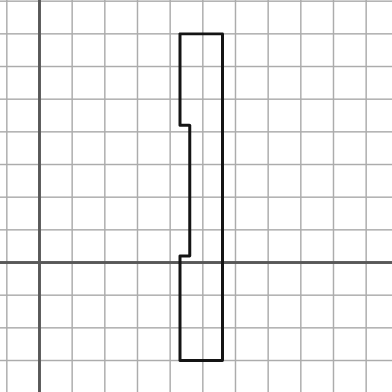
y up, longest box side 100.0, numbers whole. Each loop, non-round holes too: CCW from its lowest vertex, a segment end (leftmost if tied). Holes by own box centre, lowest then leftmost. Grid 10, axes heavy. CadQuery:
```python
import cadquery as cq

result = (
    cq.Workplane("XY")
    .moveTo(43.0, -30.0)
    .lineTo(56.0, -30.0)
    .lineTo(56.0, 70.0)
    .lineTo(43.0, 70.0)
    .lineTo(43.0, 42.0)
    .lineTo(46.0, 42.0)
    .lineTo(46.0, 2.0)
    .lineTo(43.0, 2.0)
    .close()
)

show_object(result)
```